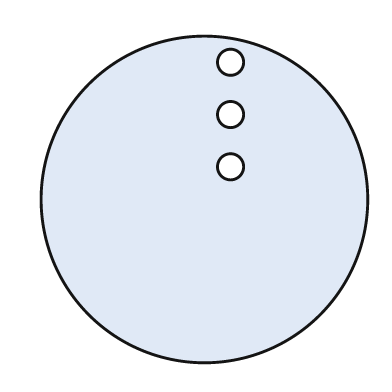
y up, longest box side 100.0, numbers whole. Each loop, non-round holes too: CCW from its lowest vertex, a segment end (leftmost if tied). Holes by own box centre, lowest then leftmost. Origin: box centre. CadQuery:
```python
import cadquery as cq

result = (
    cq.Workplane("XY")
    .moveTo(0.0, 0.0)
    .circle(50.0)
    .moveTo(8.0, 10.0)
    .circle(4.0)
    .moveTo(8.0, 26.0)
    .circle(4.0)
    .moveTo(8.0, 42.0)
    .circle(4.0)
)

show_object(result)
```